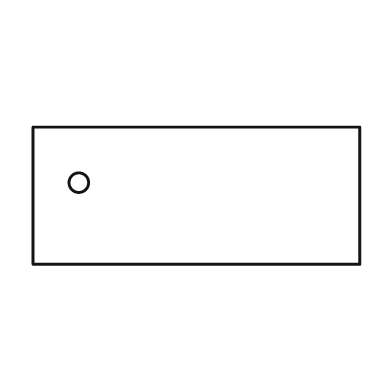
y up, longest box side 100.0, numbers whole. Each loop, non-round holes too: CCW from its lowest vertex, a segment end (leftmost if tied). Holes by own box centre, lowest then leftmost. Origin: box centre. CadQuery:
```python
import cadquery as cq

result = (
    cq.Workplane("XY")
    .moveTo(-50.0, -21.0)
    .lineTo(50.0, -21.0)
    .lineTo(50.0, 21.0)
    .lineTo(-50.0, 21.0)
    .close()
    .moveTo(-36.0, 4.0)
    .circle(3.0)
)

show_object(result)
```